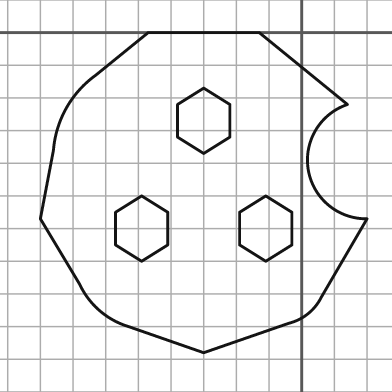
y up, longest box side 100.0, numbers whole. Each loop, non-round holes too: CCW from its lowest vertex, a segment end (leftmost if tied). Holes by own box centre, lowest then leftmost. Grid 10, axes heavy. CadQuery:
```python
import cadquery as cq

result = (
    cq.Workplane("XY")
    .moveTo(-30.0, -98.0)
    .lineTo(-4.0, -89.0)
    .threePointArc((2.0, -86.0), (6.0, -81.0))
    .lineTo(20.0, -57.0)
    .threePointArc((2.0, -42.0), (14.0, -22.0))
    .lineTo(-13.0, 0.0)
    .lineTo(-47.0, 0.0)
    .lineTo(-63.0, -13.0)
    .threePointArc((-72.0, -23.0), (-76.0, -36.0))
    .lineTo(-80.0, -57.0)
    .lineTo(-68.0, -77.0)
    .threePointArc((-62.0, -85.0), (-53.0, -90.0))
    .close()
    .moveTo(-49.0, -70.0)
    .lineTo(-41.0, -65.0)
    .lineTo(-41.0, -55.0)
    .lineTo(-49.0, -50.0)
    .lineTo(-57.0, -55.0)
    .lineTo(-57.0, -65.0)
    .close()
    .moveTo(-11.0, -70.0)
    .lineTo(-3.0, -65.0)
    .lineTo(-3.0, -55.0)
    .lineTo(-11.0, -50.0)
    .lineTo(-19.0, -55.0)
    .lineTo(-19.0, -65.0)
    .close()
    .moveTo(-30.0, -37.0)
    .lineTo(-22.0, -32.0)
    .lineTo(-22.0, -22.0)
    .lineTo(-30.0, -17.0)
    .lineTo(-38.0, -22.0)
    .lineTo(-38.0, -32.0)
    .close()
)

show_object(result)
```